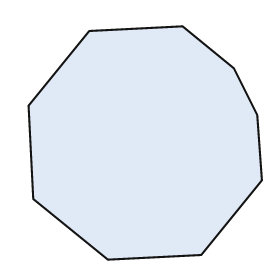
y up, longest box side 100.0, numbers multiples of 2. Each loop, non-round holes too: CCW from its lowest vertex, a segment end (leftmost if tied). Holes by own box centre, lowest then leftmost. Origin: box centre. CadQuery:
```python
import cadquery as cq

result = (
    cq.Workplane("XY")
    .moveTo(-16.0, -50.0)
    .lineTo(24.0, -48.0)
    .lineTo(50.0, -16.0)
    .lineTo(48.0, 12.0)
    .lineTo(38.0, 32.0)
    .lineTo(16.0, 50.0)
    .lineTo(-24.0, 48.0)
    .lineTo(-50.0, 16.0)
    .lineTo(-48.0, -24.0)
    .close()
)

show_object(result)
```